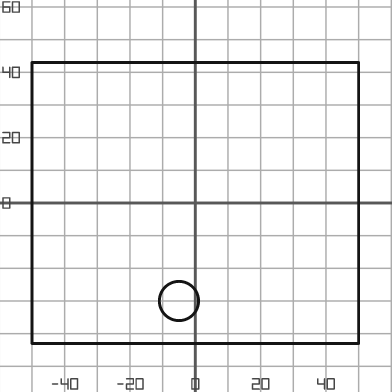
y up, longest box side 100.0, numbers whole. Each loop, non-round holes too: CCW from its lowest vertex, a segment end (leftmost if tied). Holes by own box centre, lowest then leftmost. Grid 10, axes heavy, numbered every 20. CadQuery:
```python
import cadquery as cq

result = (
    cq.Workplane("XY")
    .moveTo(-50.0, -43.0)
    .lineTo(50.0, -43.0)
    .lineTo(50.0, 43.0)
    .lineTo(-50.0, 43.0)
    .close()
    .moveTo(-5.0, -30.0)
    .circle(6.0)
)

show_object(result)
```